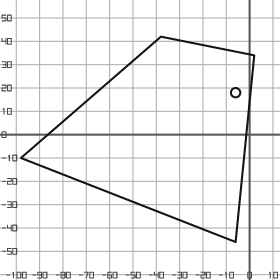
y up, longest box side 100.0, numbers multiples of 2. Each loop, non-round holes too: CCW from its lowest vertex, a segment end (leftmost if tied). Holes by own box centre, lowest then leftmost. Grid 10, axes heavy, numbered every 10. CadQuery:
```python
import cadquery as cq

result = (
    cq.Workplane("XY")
    .moveTo(-6.0, -46.0)
    .lineTo(2.0, 34.0)
    .lineTo(-38.0, 42.0)
    .lineTo(-98.0, -10.0)
    .close()
    .moveTo(-6.0, 18.0)
    .circle(2.0)
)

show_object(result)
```